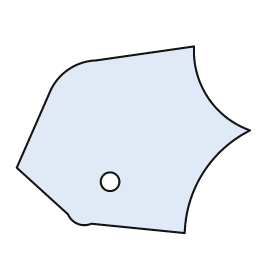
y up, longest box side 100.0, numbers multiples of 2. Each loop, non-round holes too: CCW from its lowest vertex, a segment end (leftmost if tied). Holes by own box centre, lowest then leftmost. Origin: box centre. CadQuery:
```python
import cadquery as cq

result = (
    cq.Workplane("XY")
    .moveTo(22.0, -40.0)
    .threePointArc((30.0, -14.0), (50.0, 4.0))
    .threePointArc((32.0, 18.0), (26.0, 40.0))
    .lineTo(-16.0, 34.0)
    .threePointArc((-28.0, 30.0), (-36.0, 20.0))
    .lineTo(-50.0, -12.0)
    .lineTo(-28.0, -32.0)
    .threePointArc((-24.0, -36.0), (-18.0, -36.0))
    .close()
    .moveTo(-10.0, -18.0)
    .circle(4.0)
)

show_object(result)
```